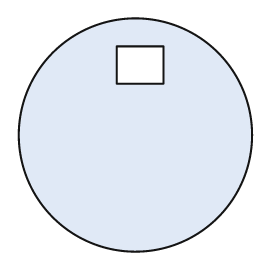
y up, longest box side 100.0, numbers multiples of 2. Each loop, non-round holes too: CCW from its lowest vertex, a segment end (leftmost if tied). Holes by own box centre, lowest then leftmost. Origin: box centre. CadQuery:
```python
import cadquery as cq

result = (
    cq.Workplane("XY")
    .moveTo(0.0, 0.0)
    .circle(50.0)
    .moveTo(-8.0, 22.0)
    .lineTo(12.0, 22.0)
    .lineTo(12.0, 38.0)
    .lineTo(-8.0, 38.0)
    .close()
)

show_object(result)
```